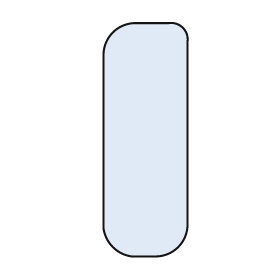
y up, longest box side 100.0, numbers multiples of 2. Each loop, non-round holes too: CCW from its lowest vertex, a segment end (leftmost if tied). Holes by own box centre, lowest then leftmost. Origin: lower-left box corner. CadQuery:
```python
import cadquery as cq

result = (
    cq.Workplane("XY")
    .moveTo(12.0, 0.0)
    .lineTo(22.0, 0.0)
    .threePointArc((32.0, 4.0), (36.0, 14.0))
    .lineTo(36.0, 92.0)
    .threePointArc((34.0, 98.0), (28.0, 100.0))
    .lineTo(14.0, 100.0)
    .threePointArc((4.0, 96.0), (0.0, 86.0))
    .lineTo(0.0, 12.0)
    .threePointArc((4.0, 4.0), (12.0, 0.0))
    .close()
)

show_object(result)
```